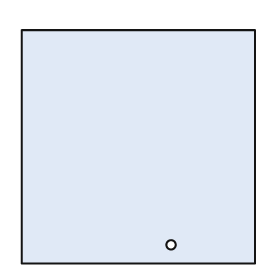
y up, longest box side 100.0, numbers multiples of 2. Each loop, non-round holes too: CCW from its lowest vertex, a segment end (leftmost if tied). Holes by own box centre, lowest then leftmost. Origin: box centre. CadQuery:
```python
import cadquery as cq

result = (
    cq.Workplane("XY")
    .moveTo(-50.0, -50.0)
    .lineTo(50.0, -50.0)
    .lineTo(50.0, 50.0)
    .lineTo(-50.0, 50.0)
    .close()
    .moveTo(14.0, -42.0)
    .circle(2.0)
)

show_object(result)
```